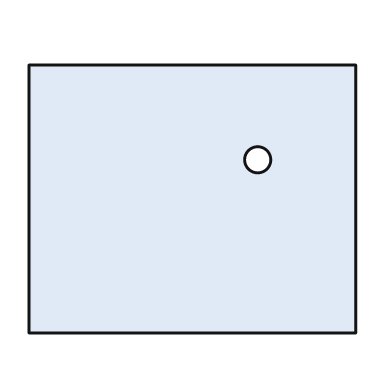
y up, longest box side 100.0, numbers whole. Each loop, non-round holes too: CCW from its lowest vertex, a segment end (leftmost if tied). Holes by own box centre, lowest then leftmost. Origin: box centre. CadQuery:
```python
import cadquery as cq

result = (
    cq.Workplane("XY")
    .moveTo(-50.0, -41.0)
    .lineTo(50.0, -41.0)
    .lineTo(50.0, 41.0)
    .lineTo(-50.0, 41.0)
    .close()
    .moveTo(20.0, 12.0)
    .circle(4.0)
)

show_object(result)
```